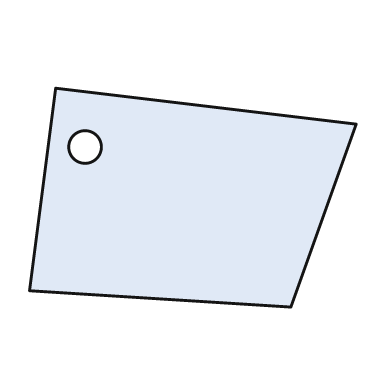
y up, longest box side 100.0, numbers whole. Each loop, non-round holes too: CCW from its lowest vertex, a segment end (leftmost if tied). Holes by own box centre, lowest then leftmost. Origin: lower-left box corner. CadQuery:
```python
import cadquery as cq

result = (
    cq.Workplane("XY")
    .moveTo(80.0, 0.0)
    .lineTo(100.0, 56.0)
    .lineTo(8.0, 67.0)
    .lineTo(0.0, 5.0)
    .close()
    .moveTo(17.0, 49.0)
    .circle(5.0)
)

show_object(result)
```